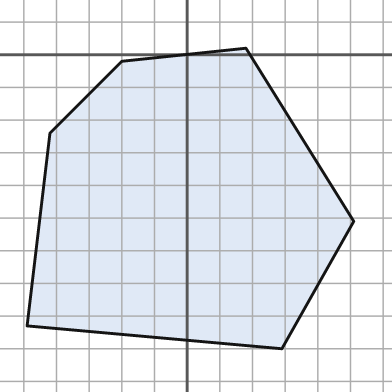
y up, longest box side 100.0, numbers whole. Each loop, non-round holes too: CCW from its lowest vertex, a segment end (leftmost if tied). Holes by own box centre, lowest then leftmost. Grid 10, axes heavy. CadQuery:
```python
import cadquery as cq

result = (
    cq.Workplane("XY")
    .moveTo(29.0, -90.0)
    .lineTo(51.0, -51.0)
    .lineTo(18.0, 2.0)
    .lineTo(-20.0, -2.0)
    .lineTo(-42.0, -24.0)
    .lineTo(-49.0, -83.0)
    .close()
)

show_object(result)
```